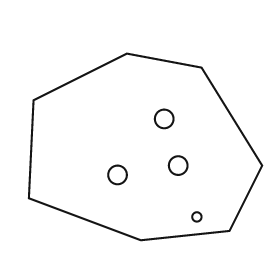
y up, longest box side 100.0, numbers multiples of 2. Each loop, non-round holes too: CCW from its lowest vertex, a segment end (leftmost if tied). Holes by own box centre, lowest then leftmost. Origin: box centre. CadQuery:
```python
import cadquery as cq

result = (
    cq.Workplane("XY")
    .moveTo(-2.0, -40.0)
    .lineTo(36.0, -36.0)
    .lineTo(50.0, -8.0)
    .lineTo(24.0, 34.0)
    .lineTo(-8.0, 40.0)
    .lineTo(-48.0, 20.0)
    .lineTo(-50.0, -22.0)
    .close()
    .moveTo(22.0, -30.0)
    .circle(2.0)
    .moveTo(-12.0, -12.0)
    .circle(4.0)
    .moveTo(14.0, -8.0)
    .circle(4.0)
    .moveTo(8.0, 12.0)
    .circle(4.0)
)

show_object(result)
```